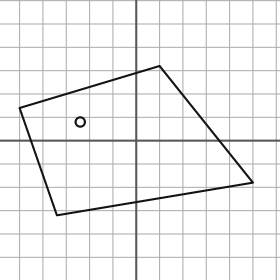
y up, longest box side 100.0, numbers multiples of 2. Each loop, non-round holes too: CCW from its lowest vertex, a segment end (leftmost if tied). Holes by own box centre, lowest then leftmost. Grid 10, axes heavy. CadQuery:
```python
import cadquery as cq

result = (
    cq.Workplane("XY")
    .moveTo(-34.0, -32.0)
    .lineTo(50.0, -18.0)
    .lineTo(10.0, 32.0)
    .lineTo(-50.0, 14.0)
    .close()
    .moveTo(-24.0, 8.0)
    .circle(2.0)
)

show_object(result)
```